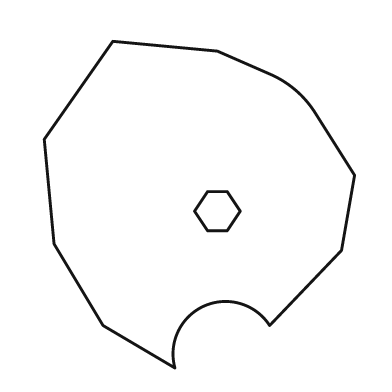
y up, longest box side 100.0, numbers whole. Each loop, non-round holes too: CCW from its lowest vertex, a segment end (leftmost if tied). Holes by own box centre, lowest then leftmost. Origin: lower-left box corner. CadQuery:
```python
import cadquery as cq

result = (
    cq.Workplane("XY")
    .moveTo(40.0, 0.0)
    .threePointArc((49.0, 19.0), (69.0, 13.0))
    .lineTo(91.0, 36.0)
    .lineTo(95.0, 59.0)
    .lineTo(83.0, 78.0)
    .threePointArc((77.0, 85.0), (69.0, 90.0))
    .lineTo(53.0, 97.0)
    .lineTo(21.0, 100.0)
    .lineTo(0.0, 70.0)
    .lineTo(3.0, 38.0)
    .lineTo(18.0, 13.0)
    .close()
    .moveTo(50.0, 42.0)
    .lineTo(56.0, 42.0)
    .lineTo(60.0, 48.0)
    .lineTo(56.0, 54.0)
    .lineTo(50.0, 54.0)
    .lineTo(46.0, 48.0)
    .close()
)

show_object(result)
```